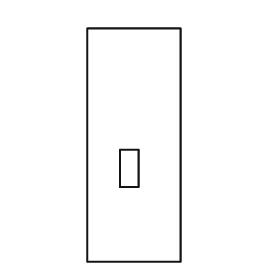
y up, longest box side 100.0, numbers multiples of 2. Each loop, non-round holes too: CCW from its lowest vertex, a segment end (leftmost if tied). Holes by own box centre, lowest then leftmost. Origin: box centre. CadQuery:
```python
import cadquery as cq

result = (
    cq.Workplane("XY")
    .moveTo(-20.0, -50.0)
    .lineTo(20.0, -50.0)
    .lineTo(20.0, 50.0)
    .lineTo(-20.0, 50.0)
    .close()
    .moveTo(-6.0, -18.0)
    .lineTo(2.0, -18.0)
    .lineTo(2.0, -2.0)
    .lineTo(-6.0, -2.0)
    .close()
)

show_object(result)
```